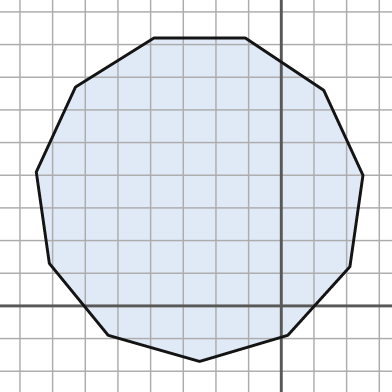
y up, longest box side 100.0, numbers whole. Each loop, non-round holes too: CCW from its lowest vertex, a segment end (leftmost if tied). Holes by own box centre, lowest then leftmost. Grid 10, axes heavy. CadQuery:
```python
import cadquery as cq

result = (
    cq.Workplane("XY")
    .moveTo(-25.0, -17.0)
    .lineTo(2.0, -9.0)
    .lineTo(21.0, 12.0)
    .lineTo(25.0, 40.0)
    .lineTo(13.0, 66.0)
    .lineTo(-11.0, 82.0)
    .lineTo(-39.0, 82.0)
    .lineTo(-63.0, 67.0)
    .lineTo(-75.0, 41.0)
    .lineTo(-71.0, 13.0)
    .lineTo(-53.0, -9.0)
    .close()
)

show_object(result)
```